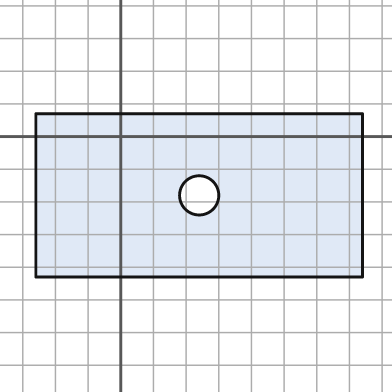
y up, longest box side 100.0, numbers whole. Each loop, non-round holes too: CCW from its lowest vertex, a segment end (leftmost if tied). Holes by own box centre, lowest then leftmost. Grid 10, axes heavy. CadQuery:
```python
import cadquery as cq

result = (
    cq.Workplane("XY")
    .moveTo(-26.0, -43.0)
    .lineTo(74.0, -43.0)
    .lineTo(74.0, 7.0)
    .lineTo(-26.0, 7.0)
    .close()
    .moveTo(24.0, -18.0)
    .circle(6.0)
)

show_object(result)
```